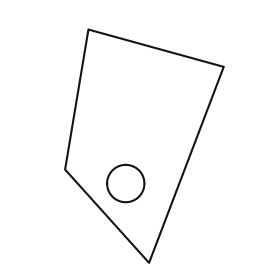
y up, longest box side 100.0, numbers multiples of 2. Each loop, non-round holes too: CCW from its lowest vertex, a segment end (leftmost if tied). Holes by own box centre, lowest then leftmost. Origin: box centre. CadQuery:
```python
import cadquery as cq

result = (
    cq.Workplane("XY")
    .moveTo(2.0, -50.0)
    .lineTo(34.0, 34.0)
    .lineTo(-24.0, 50.0)
    .lineTo(-34.0, -10.0)
    .close()
    .moveTo(-8.0, -16.0)
    .circle(8.0)
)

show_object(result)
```